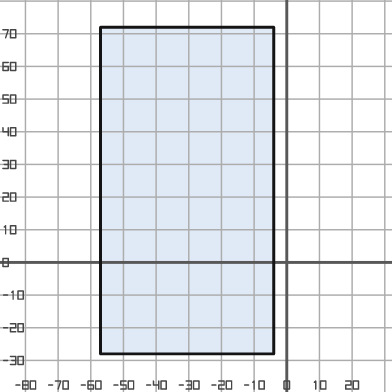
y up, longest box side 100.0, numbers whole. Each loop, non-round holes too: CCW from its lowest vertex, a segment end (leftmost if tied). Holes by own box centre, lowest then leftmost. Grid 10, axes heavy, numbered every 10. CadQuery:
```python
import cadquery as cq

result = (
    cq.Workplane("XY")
    .moveTo(-57.0, -28.0)
    .lineTo(-4.0, -28.0)
    .lineTo(-4.0, 72.0)
    .lineTo(-57.0, 72.0)
    .close()
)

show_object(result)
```